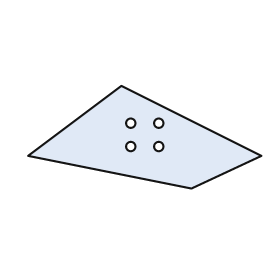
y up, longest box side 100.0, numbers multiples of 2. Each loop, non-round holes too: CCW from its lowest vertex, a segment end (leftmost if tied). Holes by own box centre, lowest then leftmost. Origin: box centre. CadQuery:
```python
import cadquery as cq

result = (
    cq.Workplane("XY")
    .moveTo(20.0, -22.0)
    .lineTo(50.0, -8.0)
    .lineTo(-10.0, 22.0)
    .lineTo(-50.0, -8.0)
    .close()
    .moveTo(-6.0, -4.0)
    .circle(2.0)
    .moveTo(6.0, -4.0)
    .circle(2.0)
    .moveTo(-6.0, 6.0)
    .circle(2.0)
    .moveTo(6.0, 6.0)
    .circle(2.0)
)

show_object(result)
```